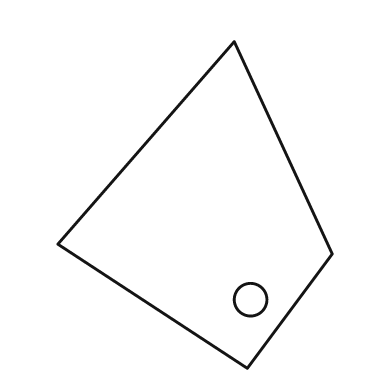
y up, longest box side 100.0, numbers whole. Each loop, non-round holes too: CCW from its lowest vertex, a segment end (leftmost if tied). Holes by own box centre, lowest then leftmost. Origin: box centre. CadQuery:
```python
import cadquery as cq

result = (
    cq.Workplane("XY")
    .moveTo(16.0, -50.0)
    .lineTo(42.0, -15.0)
    .lineTo(12.0, 50.0)
    .lineTo(-42.0, -12.0)
    .close()
    .moveTo(17.0, -29.0)
    .circle(5.0)
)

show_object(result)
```